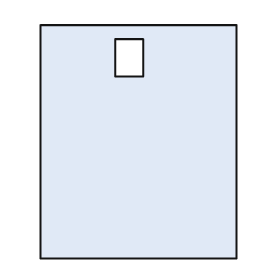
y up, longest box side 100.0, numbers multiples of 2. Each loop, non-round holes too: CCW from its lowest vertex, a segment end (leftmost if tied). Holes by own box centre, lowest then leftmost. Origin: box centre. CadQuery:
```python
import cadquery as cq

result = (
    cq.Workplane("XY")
    .moveTo(-42.0, -50.0)
    .lineTo(42.0, -50.0)
    .lineTo(42.0, 50.0)
    .lineTo(-42.0, 50.0)
    .close()
    .moveTo(-10.0, 28.0)
    .lineTo(2.0, 28.0)
    .lineTo(2.0, 44.0)
    .lineTo(-10.0, 44.0)
    .close()
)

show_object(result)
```